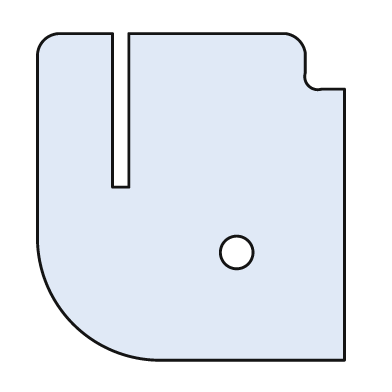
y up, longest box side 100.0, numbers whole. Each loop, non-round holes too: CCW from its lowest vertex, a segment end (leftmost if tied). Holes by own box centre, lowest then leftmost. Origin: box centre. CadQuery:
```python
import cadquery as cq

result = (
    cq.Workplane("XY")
    .moveTo(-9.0, -50.0)
    .lineTo(47.0, -50.0)
    .lineTo(47.0, 33.0)
    .lineTo(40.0, 33.0)
    .threePointArc((36.0, 34.0), (35.0, 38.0))
    .lineTo(35.0, 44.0)
    .threePointArc((33.0, 48.0), (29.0, 50.0))
    .lineTo(-19.0, 50.0)
    .lineTo(-19.0, 3.0)
    .lineTo(-24.0, 3.0)
    .lineTo(-24.0, 50.0)
    .lineTo(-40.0, 50.0)
    .threePointArc((-45.0, 48.0), (-47.0, 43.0))
    .lineTo(-47.0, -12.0)
    .threePointArc((-36.0, -39.0), (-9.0, -50.0))
    .close()
    .moveTo(14.0, -17.0)
    .circle(5.0)
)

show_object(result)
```